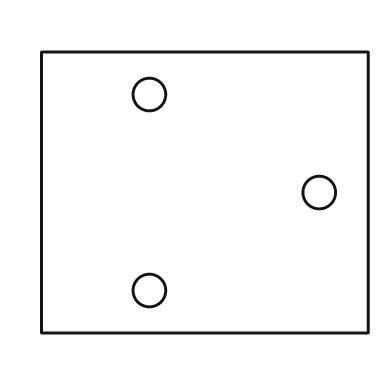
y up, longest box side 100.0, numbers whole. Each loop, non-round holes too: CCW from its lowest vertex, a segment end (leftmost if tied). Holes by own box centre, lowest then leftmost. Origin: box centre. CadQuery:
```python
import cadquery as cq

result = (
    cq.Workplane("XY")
    .moveTo(-50.0, -43.0)
    .lineTo(50.0, -43.0)
    .lineTo(50.0, 43.0)
    .lineTo(-50.0, 43.0)
    .close()
    .moveTo(-17.0, -30.0)
    .circle(5.0)
    .moveTo(35.0, 0.0)
    .circle(5.0)
    .moveTo(-17.0, 30.0)
    .circle(5.0)
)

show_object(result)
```